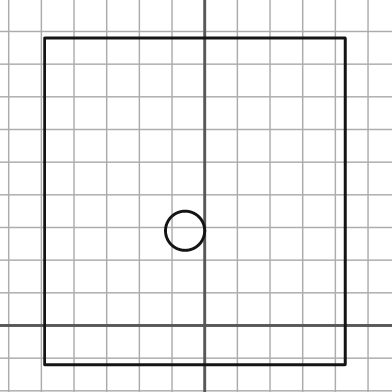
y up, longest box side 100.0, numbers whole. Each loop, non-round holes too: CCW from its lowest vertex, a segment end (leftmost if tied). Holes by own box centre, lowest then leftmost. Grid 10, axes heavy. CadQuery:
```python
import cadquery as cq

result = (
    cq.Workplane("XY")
    .moveTo(-49.0, -12.0)
    .lineTo(43.0, -12.0)
    .lineTo(43.0, 88.0)
    .lineTo(-49.0, 88.0)
    .close()
    .moveTo(-6.0, 29.0)
    .circle(6.0)
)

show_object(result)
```